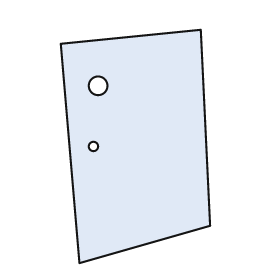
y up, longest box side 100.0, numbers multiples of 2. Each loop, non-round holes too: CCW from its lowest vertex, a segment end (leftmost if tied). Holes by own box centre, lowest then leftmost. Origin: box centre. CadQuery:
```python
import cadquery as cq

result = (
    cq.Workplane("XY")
    .moveTo(-24.0, -50.0)
    .lineTo(32.0, -34.0)
    .lineTo(28.0, 50.0)
    .lineTo(-32.0, 44.0)
    .close()
    .moveTo(-18.0, 0.0)
    .circle(2.0)
    .moveTo(-16.0, 26.0)
    .circle(4.0)
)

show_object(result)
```